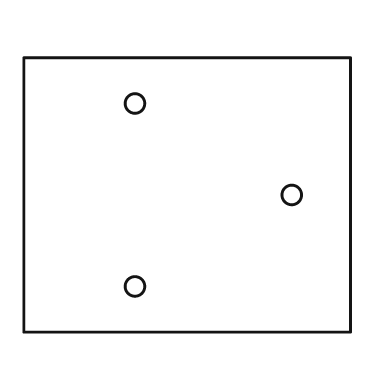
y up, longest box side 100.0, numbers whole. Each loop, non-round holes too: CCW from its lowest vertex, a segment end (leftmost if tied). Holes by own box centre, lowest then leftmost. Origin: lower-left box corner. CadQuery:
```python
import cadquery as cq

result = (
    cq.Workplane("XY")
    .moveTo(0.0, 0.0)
    .lineTo(100.0, 0.0)
    .lineTo(100.0, 84.0)
    .lineTo(0.0, 84.0)
    .close()
    .moveTo(34.0, 14.0)
    .circle(3.0)
    .moveTo(82.0, 42.0)
    .circle(3.0)
    .moveTo(34.0, 70.0)
    .circle(3.0)
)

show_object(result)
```